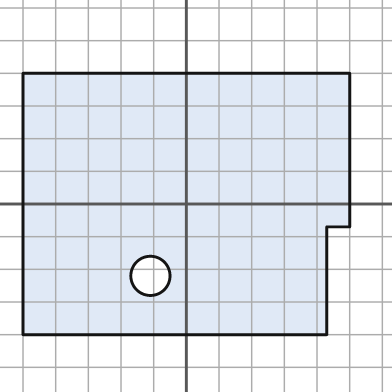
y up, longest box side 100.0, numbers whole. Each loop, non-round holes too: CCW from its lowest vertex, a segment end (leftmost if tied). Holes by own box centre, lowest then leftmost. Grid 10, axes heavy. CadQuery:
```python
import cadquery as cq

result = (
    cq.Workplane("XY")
    .moveTo(-50.0, -40.0)
    .lineTo(43.0, -40.0)
    .lineTo(43.0, -7.0)
    .lineTo(50.0, -7.0)
    .lineTo(50.0, 40.0)
    .lineTo(-50.0, 40.0)
    .close()
    .moveTo(-11.0, -22.0)
    .circle(6.0)
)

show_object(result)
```